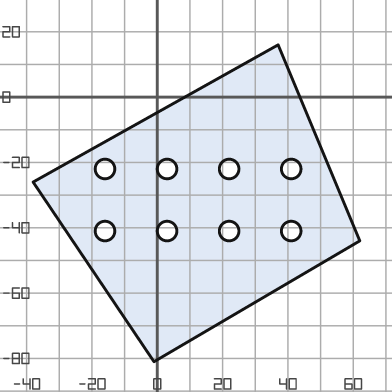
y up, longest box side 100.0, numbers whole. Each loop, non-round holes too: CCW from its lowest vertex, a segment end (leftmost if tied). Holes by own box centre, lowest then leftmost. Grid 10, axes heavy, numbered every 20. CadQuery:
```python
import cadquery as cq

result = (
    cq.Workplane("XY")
    .moveTo(-1.0, -81.0)
    .lineTo(62.0, -44.0)
    .lineTo(37.0, 16.0)
    .lineTo(-38.0, -26.0)
    .close()
    .moveTo(-16.0, -41.0)
    .circle(3.0)
    .moveTo(3.0, -41.0)
    .circle(3.0)
    .moveTo(22.0, -41.0)
    .circle(3.0)
    .moveTo(41.0, -41.0)
    .circle(3.0)
    .moveTo(-16.0, -22.0)
    .circle(3.0)
    .moveTo(3.0, -22.0)
    .circle(3.0)
    .moveTo(22.0, -22.0)
    .circle(3.0)
    .moveTo(41.0, -22.0)
    .circle(3.0)
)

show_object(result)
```